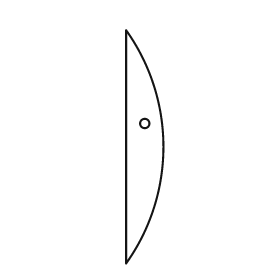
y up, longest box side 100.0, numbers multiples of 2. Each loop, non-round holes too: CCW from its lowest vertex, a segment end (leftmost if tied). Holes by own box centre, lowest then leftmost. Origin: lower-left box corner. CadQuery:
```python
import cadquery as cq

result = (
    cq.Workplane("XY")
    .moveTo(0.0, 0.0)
    .threePointArc((16.0, 50.0), (0.0, 100.0))
    .close()
    .moveTo(8.0, 60.0)
    .circle(2.0)
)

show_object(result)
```